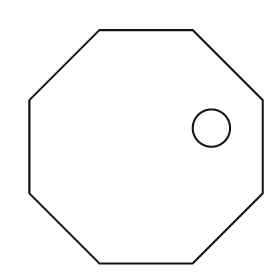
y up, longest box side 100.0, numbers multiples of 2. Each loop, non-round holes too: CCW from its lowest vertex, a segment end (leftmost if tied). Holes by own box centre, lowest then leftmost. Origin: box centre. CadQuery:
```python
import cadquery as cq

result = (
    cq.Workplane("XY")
    .moveTo(-20.0, -50.0)
    .lineTo(20.0, -50.0)
    .lineTo(50.0, -20.0)
    .lineTo(50.0, 20.0)
    .lineTo(20.0, 50.0)
    .lineTo(-20.0, 50.0)
    .lineTo(-50.0, 20.0)
    .lineTo(-50.0, -20.0)
    .close()
    .moveTo(28.0, 8.0)
    .circle(8.0)
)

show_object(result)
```